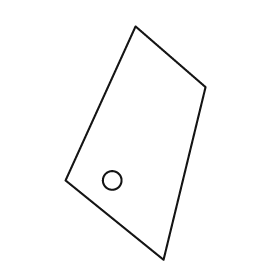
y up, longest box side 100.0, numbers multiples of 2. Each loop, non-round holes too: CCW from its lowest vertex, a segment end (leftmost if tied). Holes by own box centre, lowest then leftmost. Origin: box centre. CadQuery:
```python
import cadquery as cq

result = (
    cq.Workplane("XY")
    .moveTo(12.0, -50.0)
    .lineTo(30.0, 24.0)
    .lineTo(0.0, 50.0)
    .lineTo(-30.0, -16.0)
    .close()
    .moveTo(-10.0, -16.0)
    .circle(4.0)
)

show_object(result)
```